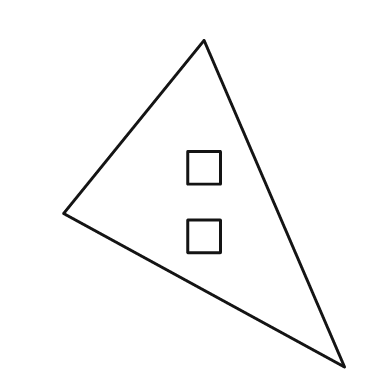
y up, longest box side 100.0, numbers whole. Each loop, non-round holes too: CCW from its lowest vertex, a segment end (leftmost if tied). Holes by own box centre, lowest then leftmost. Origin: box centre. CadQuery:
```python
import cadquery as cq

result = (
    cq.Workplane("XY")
    .moveTo(43.0, -50.0)
    .lineTo(0.0, 50.0)
    .lineTo(-43.0, -3.0)
    .close()
    .moveTo(-5.0, -15.0)
    .lineTo(5.0, -15.0)
    .lineTo(5.0, -5.0)
    .lineTo(-5.0, -5.0)
    .close()
    .moveTo(-5.0, 6.0)
    .lineTo(5.0, 6.0)
    .lineTo(5.0, 16.0)
    .lineTo(-5.0, 16.0)
    .close()
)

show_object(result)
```